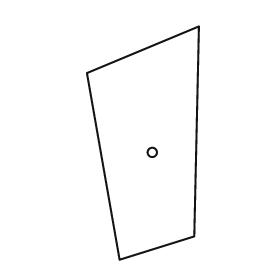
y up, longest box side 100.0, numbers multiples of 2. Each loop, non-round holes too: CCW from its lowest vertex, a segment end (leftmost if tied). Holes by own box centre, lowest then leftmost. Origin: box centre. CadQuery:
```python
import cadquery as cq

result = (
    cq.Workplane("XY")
    .moveTo(-10.0, -50.0)
    .lineTo(22.0, -40.0)
    .lineTo(24.0, 50.0)
    .lineTo(-24.0, 30.0)
    .close()
    .moveTo(4.0, -4.0)
    .circle(2.0)
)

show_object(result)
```